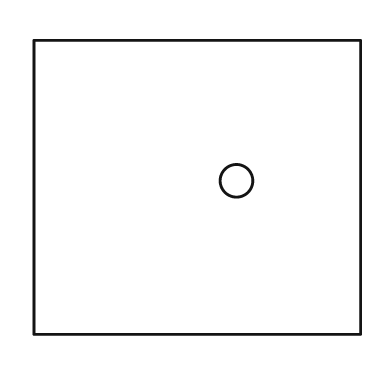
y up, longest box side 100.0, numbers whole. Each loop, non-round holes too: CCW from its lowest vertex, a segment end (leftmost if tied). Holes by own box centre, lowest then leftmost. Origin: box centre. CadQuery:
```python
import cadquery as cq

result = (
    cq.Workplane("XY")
    .moveTo(-50.0, -45.0)
    .lineTo(50.0, -45.0)
    .lineTo(50.0, 45.0)
    .lineTo(-50.0, 45.0)
    .close()
    .moveTo(12.0, 2.0)
    .circle(5.0)
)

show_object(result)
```